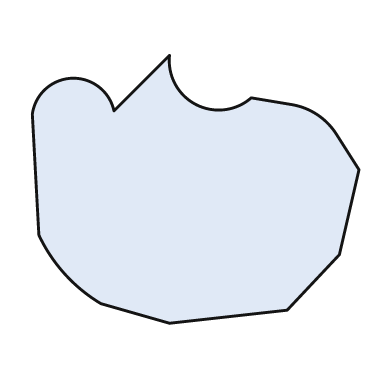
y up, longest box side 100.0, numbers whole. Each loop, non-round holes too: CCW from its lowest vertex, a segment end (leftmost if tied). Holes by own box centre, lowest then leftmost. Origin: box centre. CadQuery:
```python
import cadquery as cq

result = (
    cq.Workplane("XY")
    .moveTo(-8.0, -41.0)
    .lineTo(28.0, -37.0)
    .lineTo(44.0, -20.0)
    .lineTo(50.0, 6.0)
    .lineTo(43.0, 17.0)
    .threePointArc((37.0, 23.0), (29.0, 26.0))
    .lineTo(17.0, 28.0)
    .threePointArc((0.0, 26.0), (-8.0, 41.0))
    .lineTo(-25.0, 24.0)
    .threePointArc((-38.0, 34.0), (-50.0, 23.0))
    .lineTo(-48.0, -14.0)
    .threePointArc((-40.0, -26.0), (-29.0, -35.0))
    .close()
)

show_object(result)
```